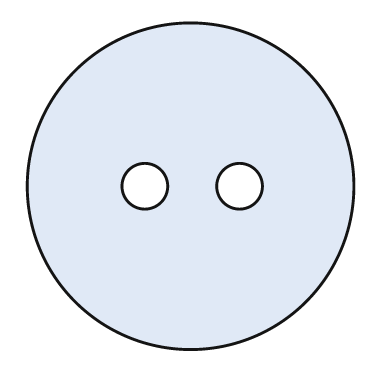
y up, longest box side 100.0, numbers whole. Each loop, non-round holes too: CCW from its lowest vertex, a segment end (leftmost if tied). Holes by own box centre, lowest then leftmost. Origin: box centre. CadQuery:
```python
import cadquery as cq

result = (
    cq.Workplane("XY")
    .moveTo(0.0, 0.0)
    .circle(50.0)
    .moveTo(-14.0, 0.0)
    .circle(7.0)
    .moveTo(15.0, 0.0)
    .circle(7.0)
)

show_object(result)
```